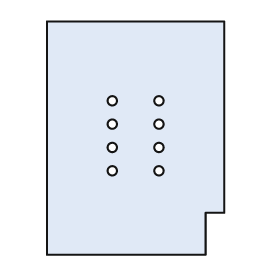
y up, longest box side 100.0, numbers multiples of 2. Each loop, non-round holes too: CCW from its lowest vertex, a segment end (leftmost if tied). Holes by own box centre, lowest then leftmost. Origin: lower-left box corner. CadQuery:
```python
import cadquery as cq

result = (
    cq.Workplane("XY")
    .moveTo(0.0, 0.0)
    .lineTo(68.0, 0.0)
    .lineTo(68.0, 18.0)
    .lineTo(76.0, 18.0)
    .lineTo(76.0, 100.0)
    .lineTo(0.0, 100.0)
    .close()
    .moveTo(28.0, 36.0)
    .circle(2.0)
    .moveTo(48.0, 36.0)
    .circle(2.0)
    .moveTo(28.0, 46.0)
    .circle(2.0)
    .moveTo(48.0, 46.0)
    .circle(2.0)
    .moveTo(28.0, 56.0)
    .circle(2.0)
    .moveTo(48.0, 56.0)
    .circle(2.0)
    .moveTo(28.0, 66.0)
    .circle(2.0)
    .moveTo(48.0, 66.0)
    .circle(2.0)
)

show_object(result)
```